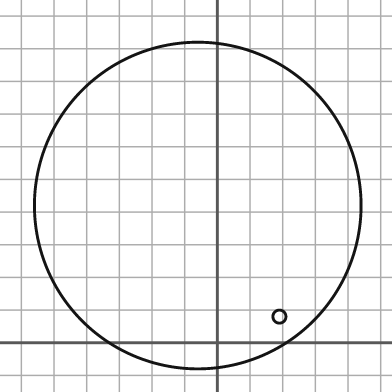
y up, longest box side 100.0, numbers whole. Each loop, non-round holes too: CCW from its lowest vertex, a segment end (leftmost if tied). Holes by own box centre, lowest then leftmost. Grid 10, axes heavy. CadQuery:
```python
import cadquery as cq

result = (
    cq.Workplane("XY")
    .moveTo(-6.0, 42.0)
    .circle(50.0)
    .moveTo(19.0, 8.0)
    .circle(2.0)
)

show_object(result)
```